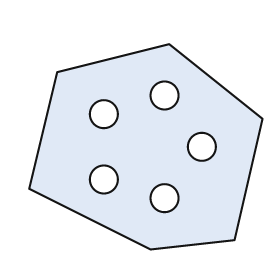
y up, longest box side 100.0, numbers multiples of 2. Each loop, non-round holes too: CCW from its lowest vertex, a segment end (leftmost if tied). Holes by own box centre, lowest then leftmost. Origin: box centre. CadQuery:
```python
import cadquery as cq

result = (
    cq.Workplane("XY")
    .moveTo(2.0, -44.0)
    .lineTo(38.0, -40.0)
    .lineTo(50.0, 12.0)
    .lineTo(10.0, 44.0)
    .lineTo(-38.0, 32.0)
    .lineTo(-50.0, -18.0)
    .close()
    .moveTo(8.0, -22.0)
    .circle(6.0)
    .moveTo(-18.0, -14.0)
    .circle(6.0)
    .moveTo(24.0, 0.0)
    .circle(6.0)
    .moveTo(-18.0, 14.0)
    .circle(6.0)
    .moveTo(8.0, 22.0)
    .circle(6.0)
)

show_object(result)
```